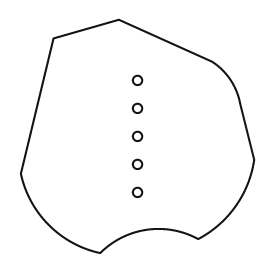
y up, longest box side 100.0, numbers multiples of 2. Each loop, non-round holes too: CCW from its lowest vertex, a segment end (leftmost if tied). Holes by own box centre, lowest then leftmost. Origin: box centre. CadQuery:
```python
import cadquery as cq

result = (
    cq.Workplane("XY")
    .moveTo(-16.0, -50.0)
    .threePointArc((4.0, -40.0), (26.0, -44.0))
    .threePointArc((42.0, -30.0), (50.0, -10.0))
    .lineTo(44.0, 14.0)
    .threePointArc((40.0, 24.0), (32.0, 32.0))
    .lineTo(-8.0, 50.0)
    .lineTo(-36.0, 42.0)
    .lineTo(-50.0, -16.0)
    .threePointArc((-38.0, -38.0), (-16.0, -50.0))
    .close()
    .moveTo(0.0, -24.0)
    .circle(2.0)
    .moveTo(0.0, -12.0)
    .circle(2.0)
    .moveTo(0.0, 0.0)
    .circle(2.0)
    .moveTo(0.0, 12.0)
    .circle(2.0)
    .moveTo(0.0, 24.0)
    .circle(2.0)
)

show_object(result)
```